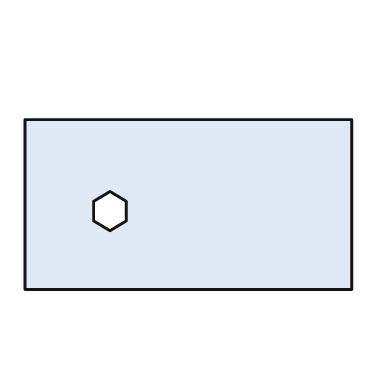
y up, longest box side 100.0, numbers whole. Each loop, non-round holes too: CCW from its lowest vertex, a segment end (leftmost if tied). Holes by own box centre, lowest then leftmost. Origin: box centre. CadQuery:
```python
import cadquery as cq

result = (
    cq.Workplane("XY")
    .moveTo(-50.0, -26.0)
    .lineTo(50.0, -26.0)
    .lineTo(50.0, 26.0)
    .lineTo(-50.0, 26.0)
    .close()
    .moveTo(-24.0, -8.0)
    .lineTo(-19.0, -5.0)
    .lineTo(-19.0, 1.0)
    .lineTo(-24.0, 4.0)
    .lineTo(-29.0, 1.0)
    .lineTo(-29.0, -5.0)
    .close()
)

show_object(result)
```